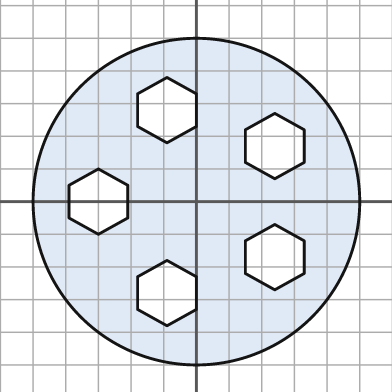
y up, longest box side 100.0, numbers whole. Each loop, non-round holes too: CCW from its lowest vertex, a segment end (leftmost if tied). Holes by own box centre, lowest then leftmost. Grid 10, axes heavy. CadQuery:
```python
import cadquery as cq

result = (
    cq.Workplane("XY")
    .moveTo(0.0, 0.0)
    .circle(50.0)
    .moveTo(-9.0, -38.0)
    .lineTo(0.0, -33.0)
    .lineTo(0.0, -23.0)
    .lineTo(-9.0, -18.0)
    .lineTo(-18.0, -23.0)
    .lineTo(-18.0, -33.0)
    .close()
    .moveTo(24.0, -27.0)
    .lineTo(33.0, -22.0)
    .lineTo(33.0, -12.0)
    .lineTo(24.0, -7.0)
    .lineTo(15.0, -12.0)
    .lineTo(15.0, -22.0)
    .close()
    .moveTo(-30.0, -10.0)
    .lineTo(-21.0, -5.0)
    .lineTo(-21.0, 5.0)
    .lineTo(-30.0, 10.0)
    .lineTo(-39.0, 5.0)
    .lineTo(-39.0, -5.0)
    .close()
    .moveTo(24.0, 7.0)
    .lineTo(33.0, 12.0)
    .lineTo(33.0, 22.0)
    .lineTo(24.0, 27.0)
    .lineTo(15.0, 22.0)
    .lineTo(15.0, 12.0)
    .close()
    .moveTo(-9.0, 18.0)
    .lineTo(0.0, 23.0)
    .lineTo(0.0, 33.0)
    .lineTo(-9.0, 38.0)
    .lineTo(-18.0, 33.0)
    .lineTo(-18.0, 23.0)
    .close()
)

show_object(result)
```